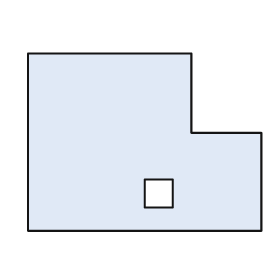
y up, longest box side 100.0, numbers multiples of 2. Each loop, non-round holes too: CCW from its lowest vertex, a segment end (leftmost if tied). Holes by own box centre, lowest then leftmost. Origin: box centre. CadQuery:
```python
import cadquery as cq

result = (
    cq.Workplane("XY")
    .moveTo(-50.0, -38.0)
    .lineTo(50.0, -38.0)
    .lineTo(50.0, 4.0)
    .lineTo(20.0, 4.0)
    .lineTo(20.0, 38.0)
    .lineTo(-50.0, 38.0)
    .close()
    .moveTo(0.0, -28.0)
    .lineTo(12.0, -28.0)
    .lineTo(12.0, -16.0)
    .lineTo(0.0, -16.0)
    .close()
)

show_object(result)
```